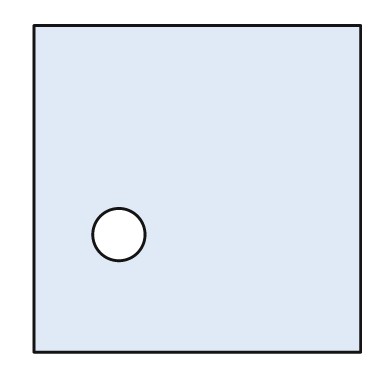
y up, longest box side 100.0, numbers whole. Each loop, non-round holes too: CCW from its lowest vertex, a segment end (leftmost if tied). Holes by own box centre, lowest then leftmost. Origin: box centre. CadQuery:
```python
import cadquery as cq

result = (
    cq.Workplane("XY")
    .moveTo(-50.0, -50.0)
    .lineTo(50.0, -50.0)
    .lineTo(50.0, 50.0)
    .lineTo(-50.0, 50.0)
    .close()
    .moveTo(-24.0, -14.0)
    .circle(8.0)
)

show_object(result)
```